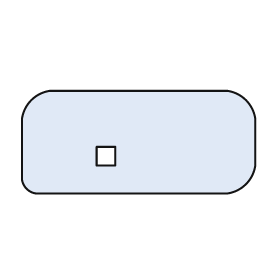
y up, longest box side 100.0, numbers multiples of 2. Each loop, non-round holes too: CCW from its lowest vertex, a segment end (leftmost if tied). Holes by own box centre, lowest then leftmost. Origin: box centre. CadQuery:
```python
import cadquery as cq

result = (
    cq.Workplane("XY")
    .moveTo(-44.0, -22.0)
    .lineTo(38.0, -22.0)
    .threePointArc((46.0, -18.0), (50.0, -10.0))
    .lineTo(50.0, 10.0)
    .threePointArc((46.0, 18.0), (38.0, 22.0))
    .lineTo(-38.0, 22.0)
    .threePointArc((-46.0, 18.0), (-50.0, 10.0))
    .lineTo(-50.0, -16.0)
    .threePointArc((-48.0, -20.0), (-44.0, -22.0))
    .close()
    .moveTo(-18.0, -10.0)
    .lineTo(-10.0, -10.0)
    .lineTo(-10.0, -2.0)
    .lineTo(-18.0, -2.0)
    .close()
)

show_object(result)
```